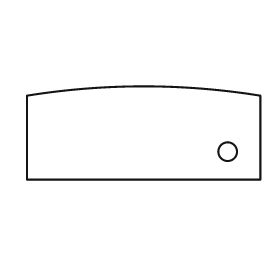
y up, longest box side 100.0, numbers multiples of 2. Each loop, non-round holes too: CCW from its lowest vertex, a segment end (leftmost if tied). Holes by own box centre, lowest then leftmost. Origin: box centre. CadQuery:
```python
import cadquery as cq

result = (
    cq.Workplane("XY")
    .moveTo(-50.0, -20.0)
    .lineTo(50.0, -20.0)
    .lineTo(50.0, 16.0)
    .threePointArc((0.0, 20.0), (-50.0, 16.0))
    .close()
    .moveTo(36.0, -8.0)
    .circle(4.0)
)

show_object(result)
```